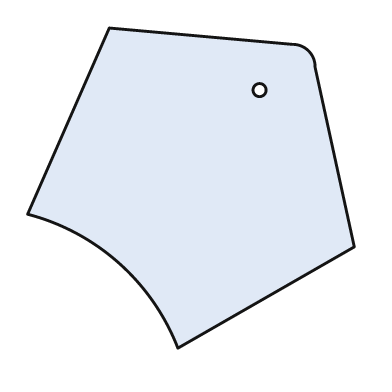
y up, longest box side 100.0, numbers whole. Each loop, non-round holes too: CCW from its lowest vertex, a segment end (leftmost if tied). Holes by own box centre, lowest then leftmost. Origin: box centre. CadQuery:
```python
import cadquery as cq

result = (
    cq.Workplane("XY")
    .moveTo(-4.0, -49.0)
    .lineTo(50.0, -18.0)
    .lineTo(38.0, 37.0)
    .threePointArc((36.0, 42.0), (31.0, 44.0))
    .lineTo(-25.0, 49.0)
    .lineTo(-50.0, -8.0)
    .threePointArc((-22.0, -23.0), (-4.0, -49.0))
    .close()
    .moveTo(21.0, 30.0)
    .circle(2.0)
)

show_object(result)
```